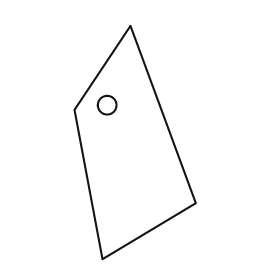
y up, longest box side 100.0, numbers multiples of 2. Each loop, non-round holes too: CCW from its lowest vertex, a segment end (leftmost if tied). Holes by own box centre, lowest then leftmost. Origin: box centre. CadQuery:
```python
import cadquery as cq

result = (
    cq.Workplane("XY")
    .moveTo(-14.0, -50.0)
    .lineTo(26.0, -26.0)
    .lineTo(-2.0, 50.0)
    .lineTo(-26.0, 14.0)
    .close()
    .moveTo(-12.0, 16.0)
    .circle(4.0)
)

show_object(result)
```